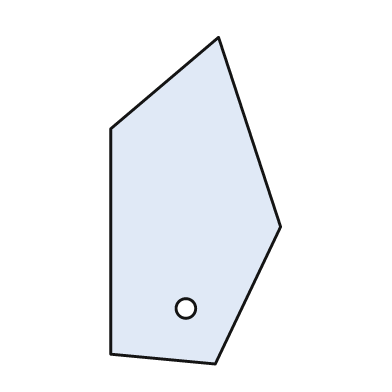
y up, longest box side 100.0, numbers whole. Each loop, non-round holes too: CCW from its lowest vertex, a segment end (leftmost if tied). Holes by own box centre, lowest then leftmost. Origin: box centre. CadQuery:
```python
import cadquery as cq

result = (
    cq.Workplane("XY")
    .moveTo(6.0, -50.0)
    .lineTo(26.0, -8.0)
    .lineTo(7.0, 50.0)
    .lineTo(-26.0, 22.0)
    .lineTo(-26.0, -47.0)
    .close()
    .moveTo(-3.0, -33.0)
    .circle(3.0)
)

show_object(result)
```